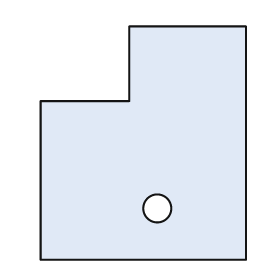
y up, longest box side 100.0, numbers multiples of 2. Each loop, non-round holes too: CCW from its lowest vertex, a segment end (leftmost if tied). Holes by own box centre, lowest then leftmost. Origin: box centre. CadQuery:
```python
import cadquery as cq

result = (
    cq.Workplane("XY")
    .moveTo(-44.0, -50.0)
    .lineTo(44.0, -50.0)
    .lineTo(44.0, 50.0)
    .lineTo(-6.0, 50.0)
    .lineTo(-6.0, 18.0)
    .lineTo(-44.0, 18.0)
    .close()
    .moveTo(6.0, -28.0)
    .circle(6.0)
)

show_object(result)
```